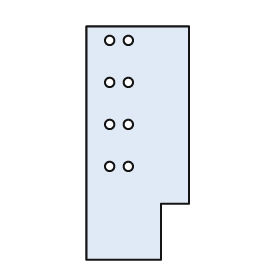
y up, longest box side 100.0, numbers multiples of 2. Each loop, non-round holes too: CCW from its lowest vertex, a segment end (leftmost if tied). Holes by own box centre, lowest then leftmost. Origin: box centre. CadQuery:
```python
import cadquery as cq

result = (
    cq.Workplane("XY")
    .moveTo(-22.0, -50.0)
    .lineTo(10.0, -50.0)
    .lineTo(10.0, -26.0)
    .lineTo(22.0, -26.0)
    .lineTo(22.0, 50.0)
    .lineTo(-22.0, 50.0)
    .close()
    .moveTo(-12.0, -10.0)
    .circle(2.0)
    .moveTo(-4.0, -10.0)
    .circle(2.0)
    .moveTo(-12.0, 8.0)
    .circle(2.0)
    .moveTo(-4.0, 8.0)
    .circle(2.0)
    .moveTo(-12.0, 26.0)
    .circle(2.0)
    .moveTo(-4.0, 26.0)
    .circle(2.0)
    .moveTo(-12.0, 44.0)
    .circle(2.0)
    .moveTo(-4.0, 44.0)
    .circle(2.0)
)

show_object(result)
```